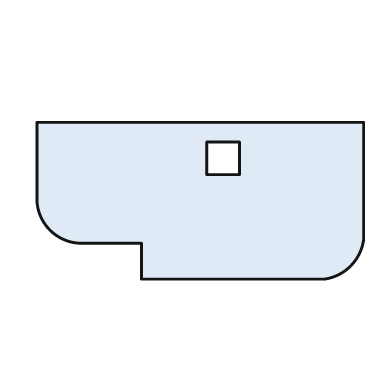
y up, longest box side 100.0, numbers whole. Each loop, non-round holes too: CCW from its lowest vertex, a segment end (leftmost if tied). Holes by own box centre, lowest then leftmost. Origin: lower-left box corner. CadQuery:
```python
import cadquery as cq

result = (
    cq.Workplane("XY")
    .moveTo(32.0, 0.0)
    .lineTo(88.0, 0.0)
    .threePointArc((96.0, 4.0), (100.0, 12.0))
    .lineTo(100.0, 48.0)
    .lineTo(0.0, 48.0)
    .lineTo(0.0, 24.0)
    .threePointArc((4.0, 15.0), (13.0, 11.0))
    .lineTo(32.0, 11.0)
    .close()
    .moveTo(52.0, 32.0)
    .lineTo(62.0, 32.0)
    .lineTo(62.0, 42.0)
    .lineTo(52.0, 42.0)
    .close()
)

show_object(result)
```